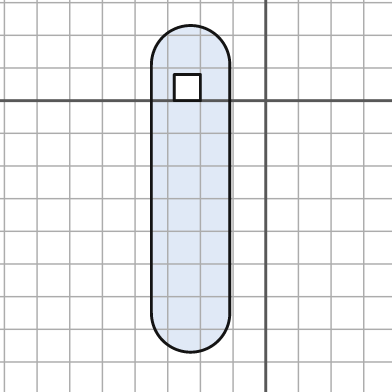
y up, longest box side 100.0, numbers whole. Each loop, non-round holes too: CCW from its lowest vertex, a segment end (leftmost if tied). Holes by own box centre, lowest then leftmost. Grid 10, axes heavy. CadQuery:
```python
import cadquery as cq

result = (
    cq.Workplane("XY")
    .moveTo(-35.0, -65.0)
    .threePointArc((-23.0, -77.0), (-11.0, -65.0))
    .lineTo(-11.0, 11.0)
    .threePointArc((-23.0, 23.0), (-35.0, 11.0))
    .close()
    .moveTo(-28.0, 0.0)
    .lineTo(-20.0, 0.0)
    .lineTo(-20.0, 8.0)
    .lineTo(-28.0, 8.0)
    .close()
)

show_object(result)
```